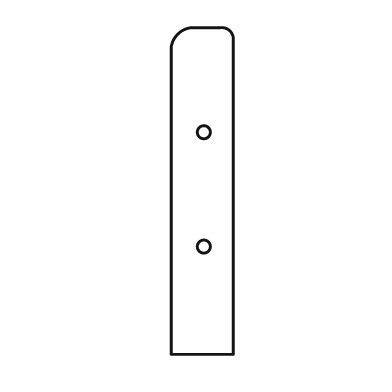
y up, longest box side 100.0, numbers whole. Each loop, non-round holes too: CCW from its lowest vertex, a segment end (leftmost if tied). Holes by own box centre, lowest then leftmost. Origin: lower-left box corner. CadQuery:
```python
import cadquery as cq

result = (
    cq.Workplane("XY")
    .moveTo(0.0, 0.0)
    .lineTo(19.0, 0.0)
    .lineTo(19.0, 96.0)
    .threePointArc((18.0, 99.0), (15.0, 100.0))
    .lineTo(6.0, 100.0)
    .threePointArc((2.0, 98.0), (0.0, 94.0))
    .close()
    .moveTo(10.0, 33.0)
    .circle(2.0)
    .moveTo(10.0, 68.0)
    .circle(2.0)
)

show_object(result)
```